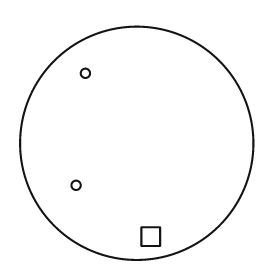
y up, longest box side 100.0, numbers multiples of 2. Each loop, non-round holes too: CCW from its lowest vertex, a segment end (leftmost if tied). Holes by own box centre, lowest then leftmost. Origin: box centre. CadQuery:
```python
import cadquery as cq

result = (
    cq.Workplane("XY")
    .moveTo(0.0, 0.0)
    .circle(50.0)
    .moveTo(2.0, -44.0)
    .lineTo(10.0, -44.0)
    .lineTo(10.0, -36.0)
    .lineTo(2.0, -36.0)
    .close()
    .moveTo(-26.0, -18.0)
    .circle(2.0)
    .moveTo(-22.0, 30.0)
    .circle(2.0)
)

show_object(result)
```